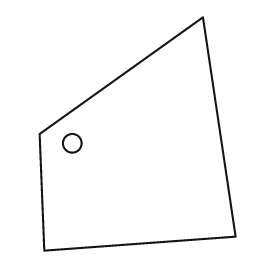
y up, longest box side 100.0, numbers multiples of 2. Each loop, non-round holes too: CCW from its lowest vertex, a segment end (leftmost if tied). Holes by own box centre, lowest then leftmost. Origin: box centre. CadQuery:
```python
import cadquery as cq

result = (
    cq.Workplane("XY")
    .moveTo(-40.0, -50.0)
    .lineTo(42.0, -44.0)
    .lineTo(28.0, 50.0)
    .lineTo(-42.0, 0.0)
    .close()
    .moveTo(-28.0, -4.0)
    .circle(4.0)
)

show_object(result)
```